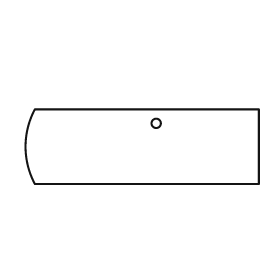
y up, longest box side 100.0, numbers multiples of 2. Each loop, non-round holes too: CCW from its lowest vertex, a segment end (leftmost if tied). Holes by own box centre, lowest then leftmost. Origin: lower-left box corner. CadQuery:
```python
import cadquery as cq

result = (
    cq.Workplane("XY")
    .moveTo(4.0, 0.0)
    .lineTo(100.0, 0.0)
    .lineTo(100.0, 32.0)
    .lineTo(4.0, 32.0)
    .threePointArc((0.0, 16.0), (4.0, 0.0))
    .close()
    .moveTo(56.0, 26.0)
    .circle(2.0)
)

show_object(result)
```